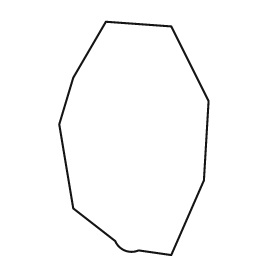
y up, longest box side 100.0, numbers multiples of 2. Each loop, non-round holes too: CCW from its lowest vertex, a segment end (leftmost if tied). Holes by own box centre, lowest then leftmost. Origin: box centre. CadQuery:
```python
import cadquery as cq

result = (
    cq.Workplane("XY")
    .moveTo(16.0, -50.0)
    .lineTo(30.0, -18.0)
    .lineTo(32.0, 16.0)
    .lineTo(16.0, 48.0)
    .lineTo(-12.0, 50.0)
    .lineTo(-26.0, 26.0)
    .lineTo(-32.0, 6.0)
    .lineTo(-26.0, -30.0)
    .lineTo(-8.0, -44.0)
    .threePointArc((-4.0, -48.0), (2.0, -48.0))
    .close()
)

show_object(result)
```